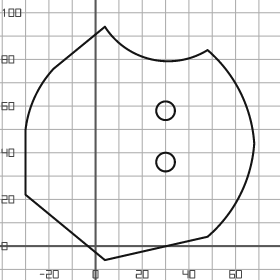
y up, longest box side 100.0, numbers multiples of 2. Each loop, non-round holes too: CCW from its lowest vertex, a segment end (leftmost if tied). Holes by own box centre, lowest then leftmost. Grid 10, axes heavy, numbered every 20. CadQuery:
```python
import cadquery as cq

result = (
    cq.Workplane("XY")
    .moveTo(4.0, -6.0)
    .lineTo(48.0, 4.0)
    .threePointArc((62.0, 22.0), (68.0, 44.0))
    .threePointArc((62.0, 66.0), (48.0, 84.0))
    .threePointArc((24.0, 80.0), (4.0, 94.0))
    .lineTo(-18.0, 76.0)
    .threePointArc((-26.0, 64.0), (-30.0, 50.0))
    .lineTo(-30.0, 22.0)
    .close()
    .moveTo(30.0, 36.0)
    .circle(4.0)
    .moveTo(30.0, 58.0)
    .circle(4.0)
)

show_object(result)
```